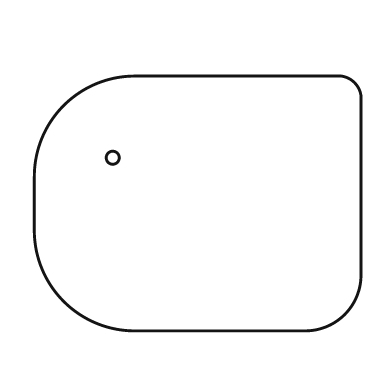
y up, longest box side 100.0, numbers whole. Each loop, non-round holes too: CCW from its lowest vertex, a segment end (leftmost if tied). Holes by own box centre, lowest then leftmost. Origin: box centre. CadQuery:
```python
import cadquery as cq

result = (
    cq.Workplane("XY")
    .moveTo(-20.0, -39.0)
    .lineTo(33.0, -39.0)
    .threePointArc((45.0, -34.0), (50.0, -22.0))
    .lineTo(50.0, 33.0)
    .threePointArc((48.0, 37.0), (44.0, 39.0))
    .lineTo(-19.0, 39.0)
    .threePointArc((-41.0, 30.0), (-50.0, 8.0))
    .lineTo(-50.0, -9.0)
    .threePointArc((-41.0, -30.0), (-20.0, -39.0))
    .close()
    .moveTo(-26.0, 14.0)
    .circle(2.0)
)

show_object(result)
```